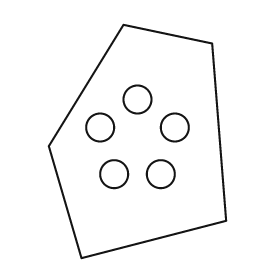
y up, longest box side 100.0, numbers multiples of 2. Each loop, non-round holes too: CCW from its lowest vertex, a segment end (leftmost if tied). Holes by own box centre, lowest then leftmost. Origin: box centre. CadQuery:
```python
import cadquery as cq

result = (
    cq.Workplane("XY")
    .moveTo(-24.0, -50.0)
    .lineTo(38.0, -34.0)
    .lineTo(32.0, 42.0)
    .lineTo(-6.0, 50.0)
    .lineTo(-38.0, -2.0)
    .close()
    .moveTo(-10.0, -14.0)
    .circle(6.0)
    .moveTo(10.0, -14.0)
    .circle(6.0)
    .moveTo(-16.0, 6.0)
    .circle(6.0)
    .moveTo(16.0, 6.0)
    .circle(6.0)
    .moveTo(0.0, 18.0)
    .circle(6.0)
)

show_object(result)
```